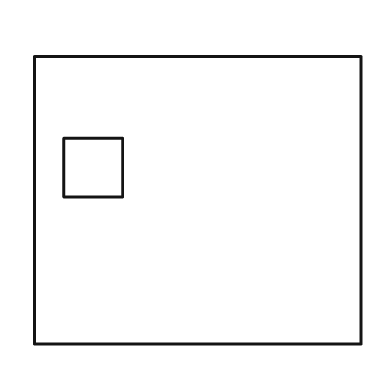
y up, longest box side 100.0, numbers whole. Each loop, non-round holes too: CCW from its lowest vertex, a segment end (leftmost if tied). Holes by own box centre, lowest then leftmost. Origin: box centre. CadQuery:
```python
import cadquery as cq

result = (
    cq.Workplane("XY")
    .moveTo(-50.0, -44.0)
    .lineTo(50.0, -44.0)
    .lineTo(50.0, 44.0)
    .lineTo(-50.0, 44.0)
    .close()
    .moveTo(-41.0, 1.0)
    .lineTo(-23.0, 1.0)
    .lineTo(-23.0, 19.0)
    .lineTo(-41.0, 19.0)
    .close()
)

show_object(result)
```